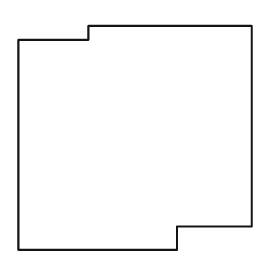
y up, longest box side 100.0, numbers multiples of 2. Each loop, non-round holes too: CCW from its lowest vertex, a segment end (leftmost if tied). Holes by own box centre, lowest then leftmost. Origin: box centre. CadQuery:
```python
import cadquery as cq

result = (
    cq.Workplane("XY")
    .moveTo(-50.0, -48.0)
    .lineTo(18.0, -48.0)
    .lineTo(18.0, -38.0)
    .lineTo(50.0, -38.0)
    .lineTo(50.0, 48.0)
    .lineTo(-20.0, 48.0)
    .lineTo(-20.0, 42.0)
    .lineTo(-50.0, 42.0)
    .close()
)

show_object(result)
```